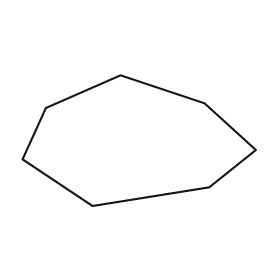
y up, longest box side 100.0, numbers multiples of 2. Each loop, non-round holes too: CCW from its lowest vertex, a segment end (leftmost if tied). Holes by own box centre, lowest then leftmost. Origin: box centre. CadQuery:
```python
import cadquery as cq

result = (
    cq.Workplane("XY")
    .moveTo(-20.0, -28.0)
    .lineTo(30.0, -20.0)
    .lineTo(50.0, -4.0)
    .lineTo(28.0, 16.0)
    .lineTo(-8.0, 28.0)
    .lineTo(-40.0, 14.0)
    .lineTo(-50.0, -8.0)
    .close()
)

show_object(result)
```